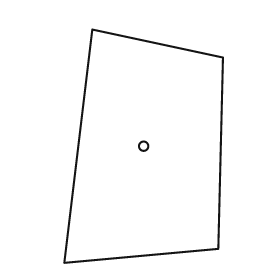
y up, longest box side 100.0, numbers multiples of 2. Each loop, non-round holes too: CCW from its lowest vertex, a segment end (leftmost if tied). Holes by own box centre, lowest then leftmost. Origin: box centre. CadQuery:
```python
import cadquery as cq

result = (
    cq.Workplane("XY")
    .moveTo(-34.0, -50.0)
    .lineTo(32.0, -44.0)
    .lineTo(34.0, 38.0)
    .lineTo(-22.0, 50.0)
    .close()
    .moveTo(0.0, 0.0)
    .circle(2.0)
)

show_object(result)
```